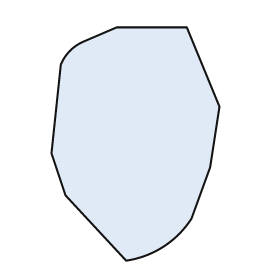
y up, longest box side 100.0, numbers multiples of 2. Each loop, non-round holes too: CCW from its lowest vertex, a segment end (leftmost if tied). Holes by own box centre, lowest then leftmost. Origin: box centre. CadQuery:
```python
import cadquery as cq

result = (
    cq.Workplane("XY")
    .moveTo(-4.0, -50.0)
    .threePointArc((12.0, -44.0), (24.0, -32.0))
    .lineTo(32.0, -10.0)
    .lineTo(36.0, 16.0)
    .lineTo(22.0, 50.0)
    .lineTo(-8.0, 50.0)
    .lineTo(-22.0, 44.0)
    .threePointArc((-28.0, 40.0), (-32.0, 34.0))
    .lineTo(-36.0, -4.0)
    .lineTo(-30.0, -22.0)
    .close()
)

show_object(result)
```